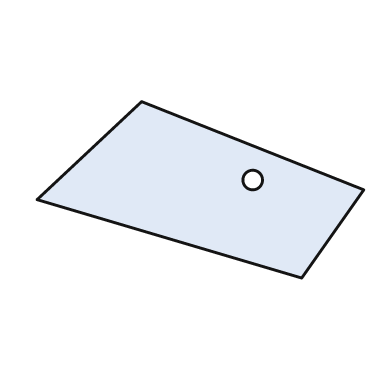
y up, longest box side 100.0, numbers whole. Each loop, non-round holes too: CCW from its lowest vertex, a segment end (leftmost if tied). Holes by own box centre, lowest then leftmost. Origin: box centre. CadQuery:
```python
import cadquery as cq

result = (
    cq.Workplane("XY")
    .moveTo(31.0, -27.0)
    .lineTo(50.0, 0.0)
    .lineTo(-18.0, 27.0)
    .lineTo(-50.0, -3.0)
    .close()
    .moveTo(16.0, 3.0)
    .circle(3.0)
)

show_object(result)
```